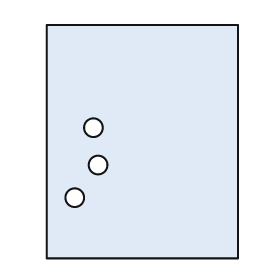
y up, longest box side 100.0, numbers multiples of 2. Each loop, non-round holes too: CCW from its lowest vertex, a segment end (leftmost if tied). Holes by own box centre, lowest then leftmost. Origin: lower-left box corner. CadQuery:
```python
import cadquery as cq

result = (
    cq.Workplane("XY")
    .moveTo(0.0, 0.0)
    .lineTo(82.0, 0.0)
    .lineTo(82.0, 100.0)
    .lineTo(0.0, 100.0)
    .close()
    .moveTo(12.0, 26.0)
    .circle(4.0)
    .moveTo(22.0, 40.0)
    .circle(4.0)
    .moveTo(20.0, 56.0)
    .circle(4.0)
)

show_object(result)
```